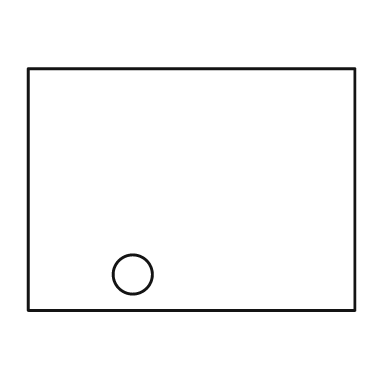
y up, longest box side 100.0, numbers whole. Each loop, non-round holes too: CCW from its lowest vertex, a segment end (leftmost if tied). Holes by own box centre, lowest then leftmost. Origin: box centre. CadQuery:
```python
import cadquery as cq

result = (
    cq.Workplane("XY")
    .moveTo(-50.0, -37.0)
    .lineTo(50.0, -37.0)
    .lineTo(50.0, 37.0)
    .lineTo(-50.0, 37.0)
    .close()
    .moveTo(-18.0, -26.0)
    .circle(6.0)
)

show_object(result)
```